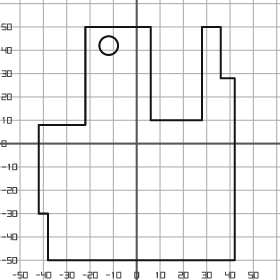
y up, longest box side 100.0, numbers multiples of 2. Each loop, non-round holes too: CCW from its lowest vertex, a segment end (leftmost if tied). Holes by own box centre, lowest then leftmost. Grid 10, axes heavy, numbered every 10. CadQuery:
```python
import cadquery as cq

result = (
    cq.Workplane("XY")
    .moveTo(-38.0, -50.0)
    .lineTo(42.0, -50.0)
    .lineTo(42.0, 28.0)
    .lineTo(36.0, 28.0)
    .lineTo(36.0, 50.0)
    .lineTo(28.0, 50.0)
    .lineTo(28.0, 10.0)
    .lineTo(6.0, 10.0)
    .lineTo(6.0, 50.0)
    .lineTo(-22.0, 50.0)
    .lineTo(-22.0, 8.0)
    .lineTo(-42.0, 8.0)
    .lineTo(-42.0, -30.0)
    .lineTo(-38.0, -30.0)
    .close()
    .moveTo(-12.0, 42.0)
    .circle(4.0)
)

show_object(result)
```